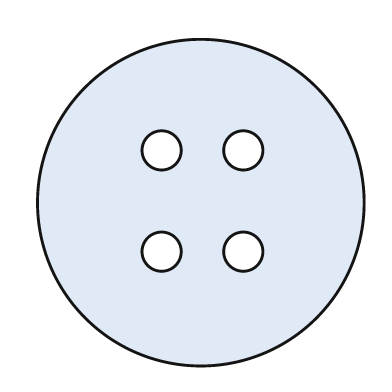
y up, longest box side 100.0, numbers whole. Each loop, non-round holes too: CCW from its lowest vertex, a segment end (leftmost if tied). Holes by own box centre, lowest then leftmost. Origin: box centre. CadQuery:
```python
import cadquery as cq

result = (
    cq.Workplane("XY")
    .moveTo(0.0, 0.0)
    .circle(50.0)
    .moveTo(-12.0, -15.0)
    .circle(6.0)
    .moveTo(13.0, -15.0)
    .circle(6.0)
    .moveTo(-12.0, 16.0)
    .circle(6.0)
    .moveTo(13.0, 16.0)
    .circle(6.0)
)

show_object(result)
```